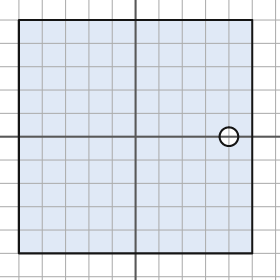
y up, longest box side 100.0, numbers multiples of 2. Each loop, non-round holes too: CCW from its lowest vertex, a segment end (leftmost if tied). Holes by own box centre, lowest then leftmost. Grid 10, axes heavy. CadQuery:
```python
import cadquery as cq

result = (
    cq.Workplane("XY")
    .moveTo(-50.0, -50.0)
    .lineTo(50.0, -50.0)
    .lineTo(50.0, 50.0)
    .lineTo(-50.0, 50.0)
    .close()
    .moveTo(40.0, 0.0)
    .circle(4.0)
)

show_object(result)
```